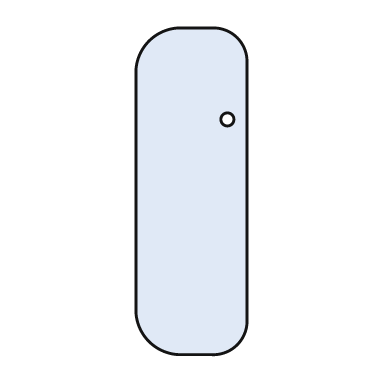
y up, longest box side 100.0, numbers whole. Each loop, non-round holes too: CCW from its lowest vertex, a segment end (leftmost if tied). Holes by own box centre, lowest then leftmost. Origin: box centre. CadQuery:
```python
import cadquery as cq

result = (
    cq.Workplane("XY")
    .moveTo(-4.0, -50.0)
    .lineTo(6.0, -50.0)
    .threePointArc((14.0, -47.0), (17.0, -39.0))
    .lineTo(17.0, 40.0)
    .threePointArc((14.0, 47.0), (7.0, 50.0))
    .lineTo(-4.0, 50.0)
    .threePointArc((-13.0, 46.0), (-17.0, 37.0))
    .lineTo(-17.0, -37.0)
    .threePointArc((-13.0, -46.0), (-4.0, -50.0))
    .close()
    .moveTo(11.0, 22.0)
    .circle(2.0)
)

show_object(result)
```